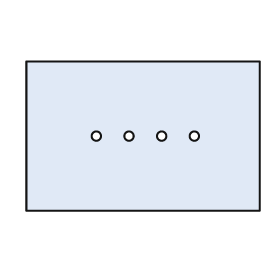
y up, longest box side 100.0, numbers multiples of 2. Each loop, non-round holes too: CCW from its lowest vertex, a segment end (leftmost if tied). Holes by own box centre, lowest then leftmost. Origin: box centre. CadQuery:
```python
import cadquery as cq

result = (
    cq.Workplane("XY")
    .moveTo(-50.0, -32.0)
    .lineTo(50.0, -32.0)
    .lineTo(50.0, 32.0)
    .lineTo(-50.0, 32.0)
    .close()
    .moveTo(-20.0, 0.0)
    .circle(2.0)
    .moveTo(-6.0, 0.0)
    .circle(2.0)
    .moveTo(8.0, 0.0)
    .circle(2.0)
    .moveTo(22.0, 0.0)
    .circle(2.0)
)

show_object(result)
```